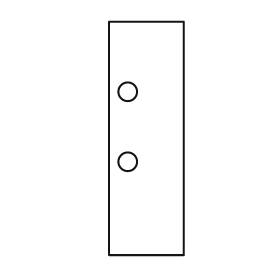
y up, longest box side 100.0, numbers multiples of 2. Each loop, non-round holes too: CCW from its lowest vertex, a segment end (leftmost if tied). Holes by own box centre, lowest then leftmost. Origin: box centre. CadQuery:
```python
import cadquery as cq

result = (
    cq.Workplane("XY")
    .moveTo(-16.0, -50.0)
    .lineTo(16.0, -50.0)
    .lineTo(16.0, 50.0)
    .lineTo(-16.0, 50.0)
    .close()
    .moveTo(-8.0, -10.0)
    .circle(4.0)
    .moveTo(-8.0, 20.0)
    .circle(4.0)
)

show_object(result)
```